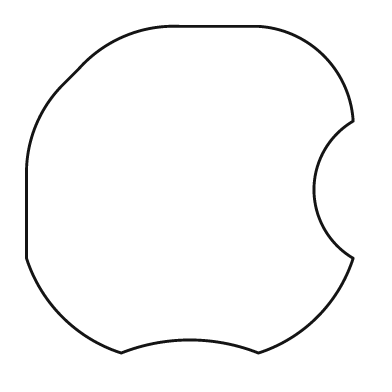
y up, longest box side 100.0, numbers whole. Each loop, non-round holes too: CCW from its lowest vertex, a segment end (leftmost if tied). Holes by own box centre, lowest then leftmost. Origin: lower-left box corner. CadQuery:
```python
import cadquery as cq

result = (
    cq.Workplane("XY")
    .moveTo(29.0, 0.0)
    .threePointArc((50.0, 4.0), (71.0, 0.0))
    .threePointArc((89.0, 11.0), (100.0, 29.0))
    .threePointArc((88.0, 50.0), (100.0, 71.0))
    .threePointArc((91.0, 91.0), (71.0, 100.0))
    .lineTo(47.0, 100.0)
    .threePointArc((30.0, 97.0), (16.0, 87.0))
    .lineTo(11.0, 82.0)
    .threePointArc((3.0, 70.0), (0.0, 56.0))
    .lineTo(0.0, 29.0)
    .threePointArc((11.0, 11.0), (29.0, 0.0))
    .close()
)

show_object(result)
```